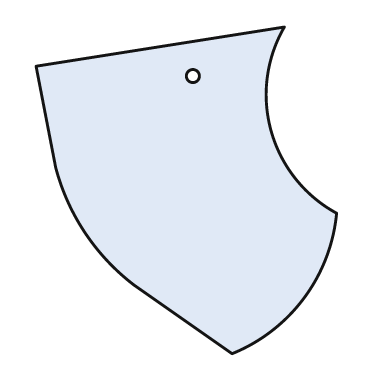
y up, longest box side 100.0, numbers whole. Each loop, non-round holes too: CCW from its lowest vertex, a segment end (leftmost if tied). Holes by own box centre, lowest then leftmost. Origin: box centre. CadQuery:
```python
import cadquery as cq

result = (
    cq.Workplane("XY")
    .moveTo(14.0, -50.0)
    .threePointArc((36.0, -33.0), (46.0, -7.0))
    .threePointArc((26.0, 18.0), (30.0, 50.0))
    .lineTo(-46.0, 38.0)
    .lineTo(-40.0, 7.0)
    .threePointArc((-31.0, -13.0), (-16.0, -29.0))
    .close()
    .moveTo(2.0, 35.0)
    .circle(2.0)
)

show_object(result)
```